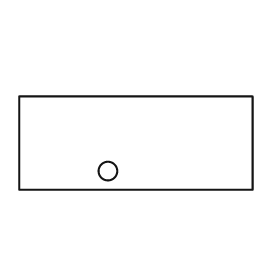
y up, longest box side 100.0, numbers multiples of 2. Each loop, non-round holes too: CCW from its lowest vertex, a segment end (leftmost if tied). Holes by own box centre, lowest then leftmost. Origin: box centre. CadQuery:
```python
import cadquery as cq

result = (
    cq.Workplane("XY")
    .moveTo(-50.0, -20.0)
    .lineTo(50.0, -20.0)
    .lineTo(50.0, 20.0)
    .lineTo(-50.0, 20.0)
    .close()
    .moveTo(-12.0, -12.0)
    .circle(4.0)
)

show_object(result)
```